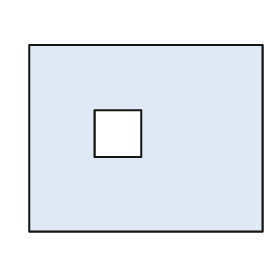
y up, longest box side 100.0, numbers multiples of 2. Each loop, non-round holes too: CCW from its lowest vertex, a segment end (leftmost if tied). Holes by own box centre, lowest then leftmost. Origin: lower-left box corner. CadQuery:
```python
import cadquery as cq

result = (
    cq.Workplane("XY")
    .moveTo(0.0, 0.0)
    .lineTo(100.0, 0.0)
    .lineTo(100.0, 80.0)
    .lineTo(0.0, 80.0)
    .close()
    .moveTo(28.0, 32.0)
    .lineTo(48.0, 32.0)
    .lineTo(48.0, 52.0)
    .lineTo(28.0, 52.0)
    .close()
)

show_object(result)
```